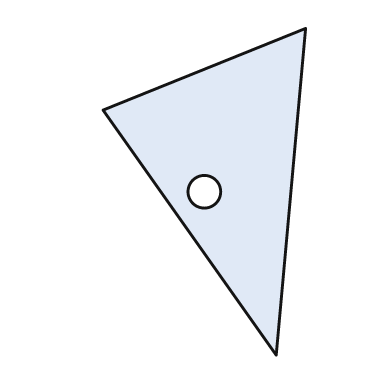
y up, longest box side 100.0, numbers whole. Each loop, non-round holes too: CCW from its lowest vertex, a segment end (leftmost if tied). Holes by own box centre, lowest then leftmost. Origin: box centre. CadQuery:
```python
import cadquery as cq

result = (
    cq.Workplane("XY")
    .moveTo(22.0, -50.0)
    .lineTo(31.0, 50.0)
    .lineTo(-31.0, 25.0)
    .close()
    .moveTo(0.0, 0.0)
    .circle(5.0)
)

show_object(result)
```